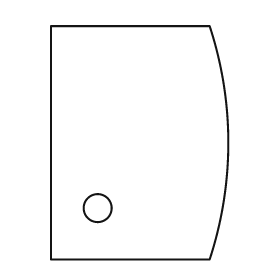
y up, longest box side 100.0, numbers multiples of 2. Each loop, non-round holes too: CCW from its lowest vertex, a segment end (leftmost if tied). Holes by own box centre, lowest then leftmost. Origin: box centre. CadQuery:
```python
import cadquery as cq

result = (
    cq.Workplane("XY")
    .moveTo(-38.0, -50.0)
    .lineTo(30.0, -50.0)
    .threePointArc((38.0, 0.0), (30.0, 50.0))
    .lineTo(-38.0, 50.0)
    .close()
    .moveTo(-18.0, -28.0)
    .circle(6.0)
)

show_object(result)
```